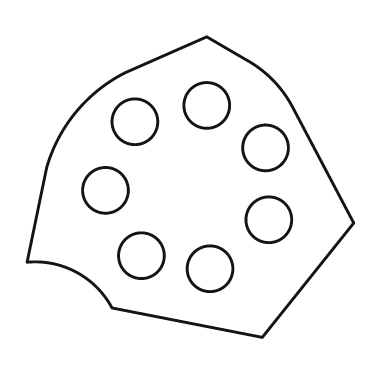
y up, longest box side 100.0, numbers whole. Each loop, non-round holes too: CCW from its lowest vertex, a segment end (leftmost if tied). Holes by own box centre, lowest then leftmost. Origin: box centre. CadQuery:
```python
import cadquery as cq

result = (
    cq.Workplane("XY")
    .moveTo(22.0, -46.0)
    .lineTo(50.0, -11.0)
    .lineTo(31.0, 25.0)
    .threePointArc((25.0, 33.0), (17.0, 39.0))
    .lineTo(5.0, 46.0)
    .lineTo(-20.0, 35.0)
    .threePointArc((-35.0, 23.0), (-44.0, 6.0))
    .lineTo(-50.0, -23.0)
    .threePointArc((-35.0, -26.0), (-24.0, -37.0))
    .close()
    .moveTo(6.0, -25.0)
    .circle(7.0)
    .moveTo(-15.0, -21.0)
    .circle(7.0)
    .moveTo(24.0, -10.0)
    .circle(7.0)
    .moveTo(-26.0, -1.0)
    .circle(7.0)
    .moveTo(23.0, 12.0)
    .circle(7.0)
    .moveTo(-17.0, 20.0)
    .circle(7.0)
    .moveTo(5.0, 25.0)
    .circle(7.0)
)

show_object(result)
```